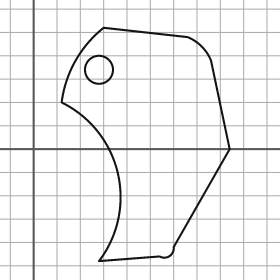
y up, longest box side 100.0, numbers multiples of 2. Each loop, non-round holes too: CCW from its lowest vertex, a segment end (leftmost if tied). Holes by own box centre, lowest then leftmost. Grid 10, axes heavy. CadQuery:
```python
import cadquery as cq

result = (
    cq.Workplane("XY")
    .moveTo(28.0, -48.0)
    .lineTo(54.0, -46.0)
    .threePointArc((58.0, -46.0), (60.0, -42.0))
    .lineTo(84.0, 0.0)
    .lineTo(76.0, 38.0)
    .threePointArc((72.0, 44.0), (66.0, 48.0))
    .lineTo(30.0, 52.0)
    .threePointArc((18.0, 38.0), (12.0, 20.0))
    .threePointArc((36.0, -10.0), (28.0, -48.0))
    .close()
    .moveTo(28.0, 34.0)
    .circle(6.0)
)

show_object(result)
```